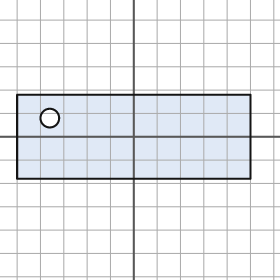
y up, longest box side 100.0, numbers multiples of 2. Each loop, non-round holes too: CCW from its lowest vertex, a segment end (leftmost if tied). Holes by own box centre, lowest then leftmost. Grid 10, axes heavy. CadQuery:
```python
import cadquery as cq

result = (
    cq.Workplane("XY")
    .moveTo(-50.0, -18.0)
    .lineTo(50.0, -18.0)
    .lineTo(50.0, 18.0)
    .lineTo(-50.0, 18.0)
    .close()
    .moveTo(-36.0, 8.0)
    .circle(4.0)
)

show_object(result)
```